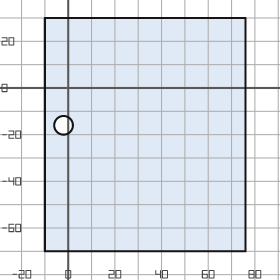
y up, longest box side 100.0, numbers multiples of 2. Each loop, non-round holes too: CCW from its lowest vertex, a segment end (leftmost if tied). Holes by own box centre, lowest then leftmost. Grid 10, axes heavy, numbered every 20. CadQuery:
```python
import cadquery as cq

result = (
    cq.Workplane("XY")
    .moveTo(-10.0, -70.0)
    .lineTo(76.0, -70.0)
    .lineTo(76.0, 30.0)
    .lineTo(-10.0, 30.0)
    .close()
    .moveTo(-2.0, -16.0)
    .circle(4.0)
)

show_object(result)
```